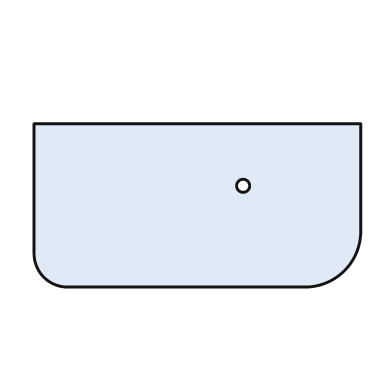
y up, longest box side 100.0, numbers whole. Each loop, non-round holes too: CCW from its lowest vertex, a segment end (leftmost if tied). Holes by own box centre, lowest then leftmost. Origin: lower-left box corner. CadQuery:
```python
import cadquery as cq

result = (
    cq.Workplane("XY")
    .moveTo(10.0, 0.0)
    .lineTo(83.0, 0.0)
    .threePointArc((95.0, 5.0), (100.0, 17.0))
    .lineTo(100.0, 50.0)
    .lineTo(0.0, 50.0)
    .lineTo(0.0, 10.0)
    .threePointArc((3.0, 3.0), (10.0, 0.0))
    .close()
    .moveTo(64.0, 31.0)
    .circle(2.0)
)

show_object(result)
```